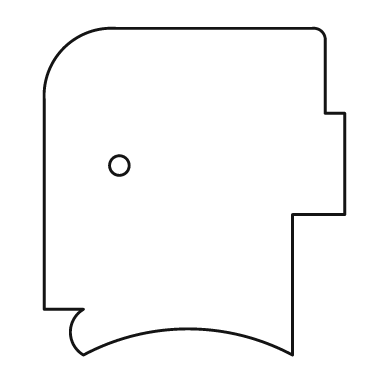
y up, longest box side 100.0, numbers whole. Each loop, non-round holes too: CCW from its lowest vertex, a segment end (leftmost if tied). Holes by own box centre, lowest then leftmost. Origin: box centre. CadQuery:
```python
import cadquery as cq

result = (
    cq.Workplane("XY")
    .moveTo(-34.0, -50.0)
    .threePointArc((-2.0, -42.0), (30.0, -50.0))
    .lineTo(30.0, -7.0)
    .lineTo(46.0, -7.0)
    .lineTo(46.0, 24.0)
    .lineTo(40.0, 24.0)
    .lineTo(40.0, 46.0)
    .threePointArc((39.0, 49.0), (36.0, 50.0))
    .lineTo(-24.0, 50.0)
    .threePointArc((-40.0, 44.0), (-46.0, 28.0))
    .lineTo(-46.0, -36.0)
    .lineTo(-34.0, -36.0)
    .threePointArc((-38.0, -43.0), (-34.0, -50.0))
    .close()
    .moveTo(-23.0, 8.0)
    .circle(3.0)
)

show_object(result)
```